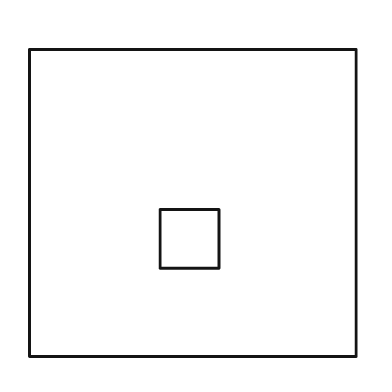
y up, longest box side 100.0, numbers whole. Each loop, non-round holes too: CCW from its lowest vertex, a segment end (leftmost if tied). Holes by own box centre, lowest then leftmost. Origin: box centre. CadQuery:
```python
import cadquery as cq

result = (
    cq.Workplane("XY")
    .moveTo(-50.0, -47.0)
    .lineTo(50.0, -47.0)
    .lineTo(50.0, 47.0)
    .lineTo(-50.0, 47.0)
    .close()
    .moveTo(-10.0, -20.0)
    .lineTo(8.0, -20.0)
    .lineTo(8.0, -2.0)
    .lineTo(-10.0, -2.0)
    .close()
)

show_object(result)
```